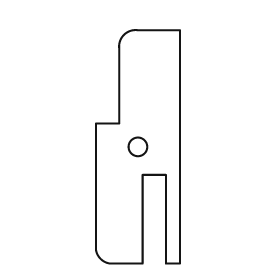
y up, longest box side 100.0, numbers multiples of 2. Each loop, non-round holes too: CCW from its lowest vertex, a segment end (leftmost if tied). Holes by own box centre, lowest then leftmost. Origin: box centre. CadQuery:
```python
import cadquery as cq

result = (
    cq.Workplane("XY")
    .moveTo(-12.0, -50.0)
    .lineTo(2.0, -50.0)
    .lineTo(2.0, -12.0)
    .lineTo(12.0, -12.0)
    .lineTo(12.0, -50.0)
    .lineTo(18.0, -50.0)
    .lineTo(18.0, 50.0)
    .lineTo(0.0, 50.0)
    .threePointArc((-6.0, 48.0), (-8.0, 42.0))
    .lineTo(-8.0, 10.0)
    .lineTo(-18.0, 10.0)
    .lineTo(-18.0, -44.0)
    .threePointArc((-16.0, -48.0), (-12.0, -50.0))
    .close()
    .moveTo(0.0, 0.0)
    .circle(4.0)
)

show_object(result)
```